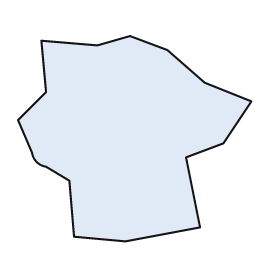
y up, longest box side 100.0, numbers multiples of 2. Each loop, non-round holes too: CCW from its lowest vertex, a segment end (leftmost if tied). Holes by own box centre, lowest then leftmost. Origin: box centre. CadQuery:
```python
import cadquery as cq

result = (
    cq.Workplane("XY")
    .moveTo(-4.0, -44.0)
    .lineTo(28.0, -38.0)
    .lineTo(22.0, -8.0)
    .lineTo(38.0, -2.0)
    .lineTo(50.0, 16.0)
    .lineTo(30.0, 24.0)
    .lineTo(14.0, 38.0)
    .lineTo(-2.0, 44.0)
    .lineTo(-16.0, 40.0)
    .lineTo(-40.0, 42.0)
    .lineTo(-38.0, 20.0)
    .lineTo(-50.0, 8.0)
    .lineTo(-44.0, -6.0)
    .threePointArc((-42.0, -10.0), (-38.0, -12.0))
    .lineTo(-28.0, -18.0)
    .lineTo(-26.0, -42.0)
    .close()
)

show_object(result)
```